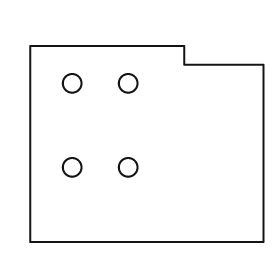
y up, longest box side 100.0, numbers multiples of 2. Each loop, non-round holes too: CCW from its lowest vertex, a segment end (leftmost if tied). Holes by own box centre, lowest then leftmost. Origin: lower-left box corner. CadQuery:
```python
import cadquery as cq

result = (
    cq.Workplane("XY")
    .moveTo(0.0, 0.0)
    .lineTo(100.0, 0.0)
    .lineTo(100.0, 76.0)
    .lineTo(66.0, 76.0)
    .lineTo(66.0, 84.0)
    .lineTo(0.0, 84.0)
    .close()
    .moveTo(18.0, 32.0)
    .circle(4.0)
    .moveTo(42.0, 32.0)
    .circle(4.0)
    .moveTo(18.0, 68.0)
    .circle(4.0)
    .moveTo(42.0, 68.0)
    .circle(4.0)
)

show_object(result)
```